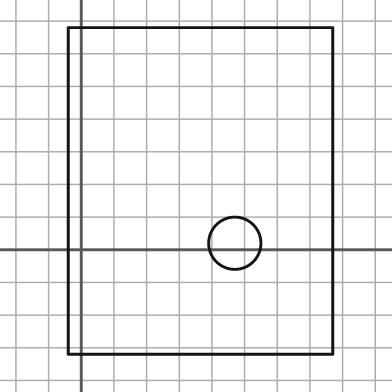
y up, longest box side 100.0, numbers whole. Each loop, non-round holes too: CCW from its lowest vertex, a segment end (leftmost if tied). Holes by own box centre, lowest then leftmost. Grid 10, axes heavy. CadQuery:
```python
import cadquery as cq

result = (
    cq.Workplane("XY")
    .moveTo(-4.0, -32.0)
    .lineTo(77.0, -32.0)
    .lineTo(77.0, 68.0)
    .lineTo(-4.0, 68.0)
    .close()
    .moveTo(47.0, 2.0)
    .circle(8.0)
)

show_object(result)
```